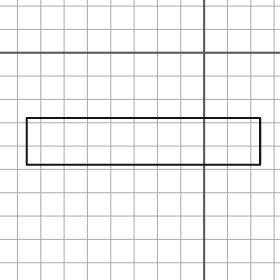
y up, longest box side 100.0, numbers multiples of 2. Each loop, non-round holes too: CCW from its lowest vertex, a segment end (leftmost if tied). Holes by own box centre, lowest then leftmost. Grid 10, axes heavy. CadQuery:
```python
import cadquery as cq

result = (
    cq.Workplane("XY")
    .moveTo(-76.0, -48.0)
    .lineTo(24.0, -48.0)
    .lineTo(24.0, -28.0)
    .lineTo(-76.0, -28.0)
    .close()
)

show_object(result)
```